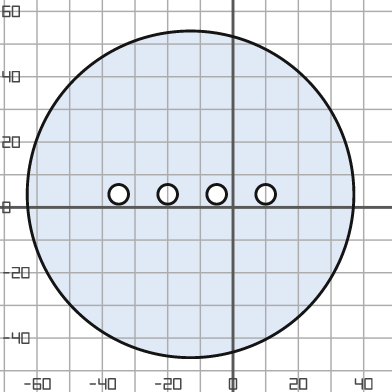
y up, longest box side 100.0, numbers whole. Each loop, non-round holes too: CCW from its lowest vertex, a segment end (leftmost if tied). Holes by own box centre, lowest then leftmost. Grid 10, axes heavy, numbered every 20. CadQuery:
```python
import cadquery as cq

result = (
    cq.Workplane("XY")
    .moveTo(-13.0, 4.0)
    .circle(50.0)
    .moveTo(-35.0, 4.0)
    .circle(3.0)
    .moveTo(-20.0, 4.0)
    .circle(3.0)
    .moveTo(-5.0, 4.0)
    .circle(3.0)
    .moveTo(10.0, 4.0)
    .circle(3.0)
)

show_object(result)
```